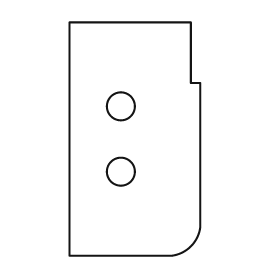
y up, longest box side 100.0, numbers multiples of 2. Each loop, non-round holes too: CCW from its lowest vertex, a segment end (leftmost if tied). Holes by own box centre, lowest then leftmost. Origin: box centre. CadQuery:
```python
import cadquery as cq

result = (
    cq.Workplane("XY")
    .moveTo(-28.0, -50.0)
    .lineTo(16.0, -50.0)
    .threePointArc((24.0, -46.0), (28.0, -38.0))
    .lineTo(28.0, 24.0)
    .lineTo(24.0, 24.0)
    .lineTo(24.0, 50.0)
    .lineTo(-28.0, 50.0)
    .close()
    .moveTo(-6.0, -14.0)
    .circle(6.0)
    .moveTo(-6.0, 14.0)
    .circle(6.0)
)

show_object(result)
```